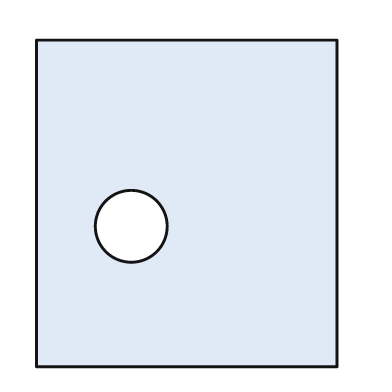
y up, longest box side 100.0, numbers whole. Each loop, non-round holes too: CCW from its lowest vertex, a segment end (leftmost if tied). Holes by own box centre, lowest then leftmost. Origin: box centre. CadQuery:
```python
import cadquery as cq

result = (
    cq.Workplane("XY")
    .moveTo(-46.0, -50.0)
    .lineTo(46.0, -50.0)
    .lineTo(46.0, 50.0)
    .lineTo(-46.0, 50.0)
    .close()
    .moveTo(-17.0, -7.0)
    .circle(11.0)
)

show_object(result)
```